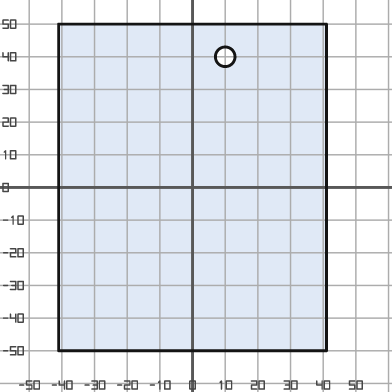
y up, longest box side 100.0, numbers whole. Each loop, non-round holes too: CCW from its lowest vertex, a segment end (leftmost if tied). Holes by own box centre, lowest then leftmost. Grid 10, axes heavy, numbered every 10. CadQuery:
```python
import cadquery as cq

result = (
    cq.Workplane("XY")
    .moveTo(-41.0, -50.0)
    .lineTo(41.0, -50.0)
    .lineTo(41.0, 50.0)
    .lineTo(-41.0, 50.0)
    .close()
    .moveTo(10.0, 40.0)
    .circle(3.0)
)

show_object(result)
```